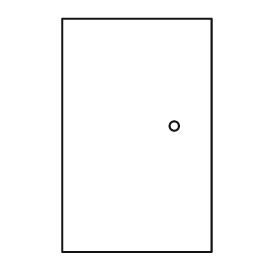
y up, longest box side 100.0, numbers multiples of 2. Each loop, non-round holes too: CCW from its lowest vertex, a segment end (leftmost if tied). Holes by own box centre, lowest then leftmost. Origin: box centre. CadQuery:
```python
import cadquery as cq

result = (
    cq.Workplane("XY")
    .moveTo(-32.0, -50.0)
    .lineTo(32.0, -50.0)
    .lineTo(32.0, 50.0)
    .lineTo(-32.0, 50.0)
    .close()
    .moveTo(16.0, 4.0)
    .circle(2.0)
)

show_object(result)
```